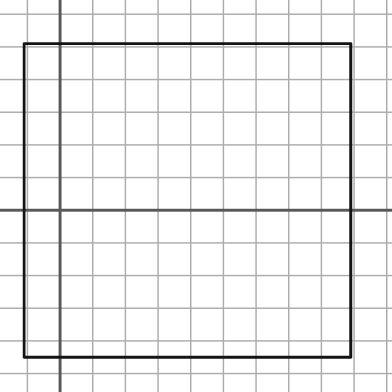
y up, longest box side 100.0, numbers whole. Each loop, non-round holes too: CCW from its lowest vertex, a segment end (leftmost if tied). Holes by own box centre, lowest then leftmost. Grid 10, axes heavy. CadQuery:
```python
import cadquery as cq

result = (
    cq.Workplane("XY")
    .moveTo(-11.0, -45.0)
    .lineTo(89.0, -45.0)
    .lineTo(89.0, 51.0)
    .lineTo(-11.0, 51.0)
    .close()
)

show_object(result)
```